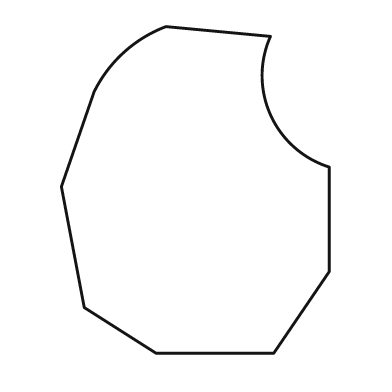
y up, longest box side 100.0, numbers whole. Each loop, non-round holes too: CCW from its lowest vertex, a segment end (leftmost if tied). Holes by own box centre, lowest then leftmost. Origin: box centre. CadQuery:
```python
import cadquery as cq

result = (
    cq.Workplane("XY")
    .moveTo(-12.0, -50.0)
    .lineTo(24.0, -50.0)
    .lineTo(41.0, -25.0)
    .lineTo(41.0, 7.0)
    .threePointArc((23.0, 23.0), (23.0, 47.0))
    .lineTo(-9.0, 50.0)
    .threePointArc((-22.0, 42.0), (-31.0, 30.0))
    .lineTo(-41.0, 1.0)
    .lineTo(-34.0, -36.0)
    .close()
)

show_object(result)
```